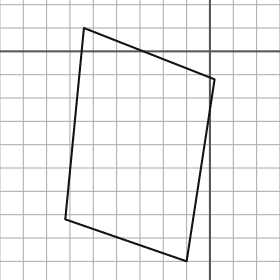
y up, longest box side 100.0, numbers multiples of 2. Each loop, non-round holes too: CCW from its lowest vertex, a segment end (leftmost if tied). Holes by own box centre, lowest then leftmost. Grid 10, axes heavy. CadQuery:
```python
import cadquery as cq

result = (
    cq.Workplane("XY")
    .moveTo(-10.0, -90.0)
    .lineTo(2.0, -12.0)
    .lineTo(-54.0, 10.0)
    .lineTo(-62.0, -72.0)
    .close()
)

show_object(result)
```